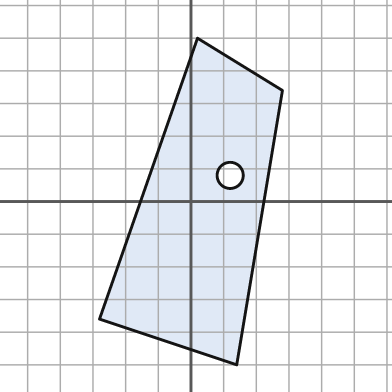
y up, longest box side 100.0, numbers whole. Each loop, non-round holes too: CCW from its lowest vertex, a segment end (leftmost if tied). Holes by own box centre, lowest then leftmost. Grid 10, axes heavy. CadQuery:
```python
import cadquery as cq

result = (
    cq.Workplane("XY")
    .moveTo(14.0, -50.0)
    .lineTo(28.0, 34.0)
    .lineTo(2.0, 50.0)
    .lineTo(-28.0, -36.0)
    .close()
    .moveTo(12.0, 8.0)
    .circle(4.0)
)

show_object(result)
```